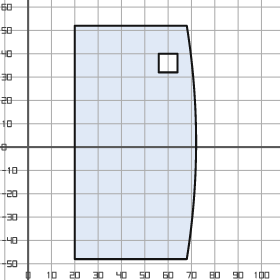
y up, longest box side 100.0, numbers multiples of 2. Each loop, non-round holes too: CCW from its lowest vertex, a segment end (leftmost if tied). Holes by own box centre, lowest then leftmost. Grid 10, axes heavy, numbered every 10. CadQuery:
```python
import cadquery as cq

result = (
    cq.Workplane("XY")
    .moveTo(20.0, -48.0)
    .lineTo(68.0, -48.0)
    .threePointArc((72.0, 2.0), (68.0, 52.0))
    .lineTo(20.0, 52.0)
    .close()
    .moveTo(56.0, 32.0)
    .lineTo(64.0, 32.0)
    .lineTo(64.0, 40.0)
    .lineTo(56.0, 40.0)
    .close()
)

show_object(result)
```